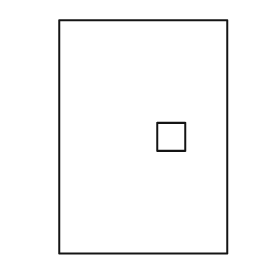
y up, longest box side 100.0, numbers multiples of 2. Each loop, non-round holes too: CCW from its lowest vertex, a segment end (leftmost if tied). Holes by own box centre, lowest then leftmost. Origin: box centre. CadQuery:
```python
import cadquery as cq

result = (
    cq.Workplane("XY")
    .moveTo(-36.0, -50.0)
    .lineTo(36.0, -50.0)
    .lineTo(36.0, 50.0)
    .lineTo(-36.0, 50.0)
    .close()
    .moveTo(6.0, -6.0)
    .lineTo(18.0, -6.0)
    .lineTo(18.0, 6.0)
    .lineTo(6.0, 6.0)
    .close()
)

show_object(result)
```